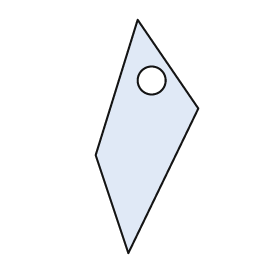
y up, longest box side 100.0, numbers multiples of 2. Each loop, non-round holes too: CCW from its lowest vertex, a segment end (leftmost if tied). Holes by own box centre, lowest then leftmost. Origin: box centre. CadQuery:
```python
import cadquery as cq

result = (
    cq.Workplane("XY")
    .moveTo(-8.0, -50.0)
    .lineTo(22.0, 12.0)
    .lineTo(-4.0, 50.0)
    .lineTo(-22.0, -8.0)
    .close()
    .moveTo(2.0, 24.0)
    .circle(6.0)
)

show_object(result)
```